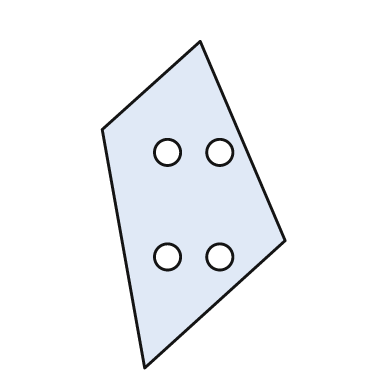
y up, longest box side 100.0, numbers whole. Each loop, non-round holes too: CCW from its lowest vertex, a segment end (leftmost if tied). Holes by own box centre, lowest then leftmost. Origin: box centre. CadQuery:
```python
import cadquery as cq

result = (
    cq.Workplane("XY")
    .moveTo(-15.0, -50.0)
    .lineTo(28.0, -11.0)
    .lineTo(2.0, 50.0)
    .lineTo(-28.0, 23.0)
    .close()
    .moveTo(-8.0, -16.0)
    .circle(4.0)
    .moveTo(8.0, -16.0)
    .circle(4.0)
    .moveTo(-8.0, 16.0)
    .circle(4.0)
    .moveTo(8.0, 16.0)
    .circle(4.0)
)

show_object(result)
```